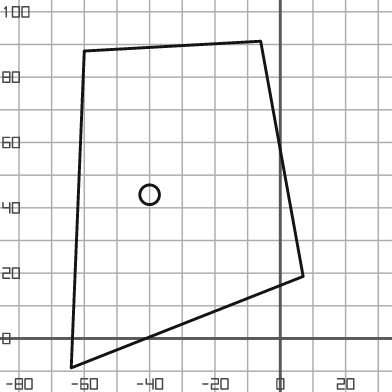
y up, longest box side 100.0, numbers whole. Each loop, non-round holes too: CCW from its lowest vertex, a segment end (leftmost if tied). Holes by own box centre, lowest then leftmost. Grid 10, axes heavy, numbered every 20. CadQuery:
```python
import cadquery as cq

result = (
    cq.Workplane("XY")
    .moveTo(-64.0, -9.0)
    .lineTo(7.0, 19.0)
    .lineTo(-6.0, 91.0)
    .lineTo(-60.0, 88.0)
    .close()
    .moveTo(-40.0, 44.0)
    .circle(3.0)
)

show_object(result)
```